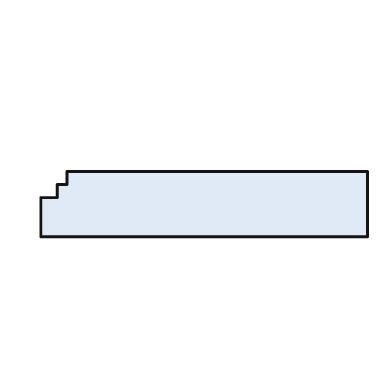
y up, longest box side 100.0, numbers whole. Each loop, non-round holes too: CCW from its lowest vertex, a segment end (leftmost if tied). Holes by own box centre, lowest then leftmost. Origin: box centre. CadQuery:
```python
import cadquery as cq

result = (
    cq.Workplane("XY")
    .moveTo(-50.0, -10.0)
    .lineTo(50.0, -10.0)
    .lineTo(50.0, 10.0)
    .lineTo(-42.0, 10.0)
    .lineTo(-42.0, 6.0)
    .lineTo(-45.0, 6.0)
    .lineTo(-45.0, 2.0)
    .lineTo(-50.0, 2.0)
    .close()
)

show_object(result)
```